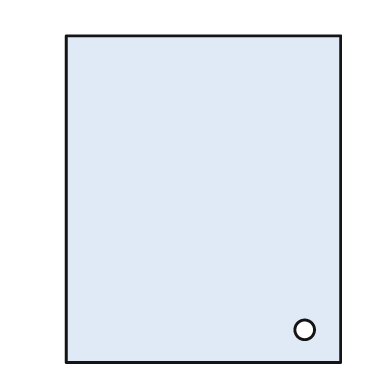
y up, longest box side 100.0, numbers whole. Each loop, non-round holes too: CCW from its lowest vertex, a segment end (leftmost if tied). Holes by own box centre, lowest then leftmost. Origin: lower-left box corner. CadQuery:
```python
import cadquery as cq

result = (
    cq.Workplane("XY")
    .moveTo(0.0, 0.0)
    .lineTo(84.0, 0.0)
    .lineTo(84.0, 100.0)
    .lineTo(0.0, 100.0)
    .close()
    .moveTo(73.0, 10.0)
    .circle(3.0)
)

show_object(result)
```